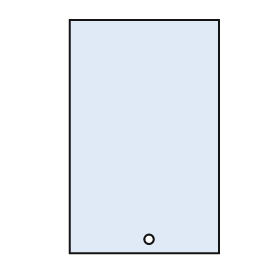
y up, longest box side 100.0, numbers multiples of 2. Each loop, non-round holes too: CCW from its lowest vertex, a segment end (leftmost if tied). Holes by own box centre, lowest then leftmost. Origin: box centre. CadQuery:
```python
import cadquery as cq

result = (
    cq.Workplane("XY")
    .moveTo(-32.0, -50.0)
    .lineTo(32.0, -50.0)
    .lineTo(32.0, 50.0)
    .lineTo(-32.0, 50.0)
    .close()
    .moveTo(2.0, -44.0)
    .circle(2.0)
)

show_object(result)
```